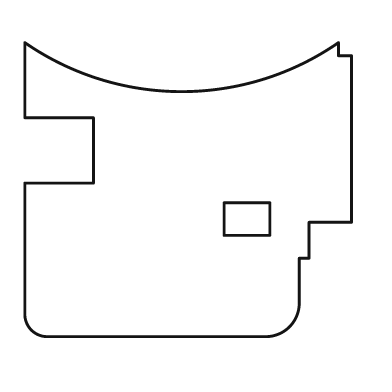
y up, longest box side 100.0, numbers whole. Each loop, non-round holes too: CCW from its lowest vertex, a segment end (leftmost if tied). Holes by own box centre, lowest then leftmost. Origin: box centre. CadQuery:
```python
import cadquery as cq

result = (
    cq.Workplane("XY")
    .moveTo(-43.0, -45.0)
    .lineTo(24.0, -45.0)
    .threePointArc((31.0, -42.0), (34.0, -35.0))
    .lineTo(34.0, -21.0)
    .lineTo(37.0, -21.0)
    .lineTo(37.0, -10.0)
    .lineTo(50.0, -10.0)
    .lineTo(50.0, 41.0)
    .lineTo(46.0, 41.0)
    .lineTo(46.0, 45.0)
    .threePointArc((-2.0, 30.0), (-50.0, 45.0))
    .lineTo(-50.0, 22.0)
    .lineTo(-29.0, 22.0)
    .lineTo(-29.0, 2.0)
    .lineTo(-50.0, 2.0)
    .lineTo(-50.0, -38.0)
    .threePointArc((-48.0, -43.0), (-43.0, -45.0))
    .close()
    .moveTo(11.0, -14.0)
    .lineTo(25.0, -14.0)
    .lineTo(25.0, -4.0)
    .lineTo(11.0, -4.0)
    .close()
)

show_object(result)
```